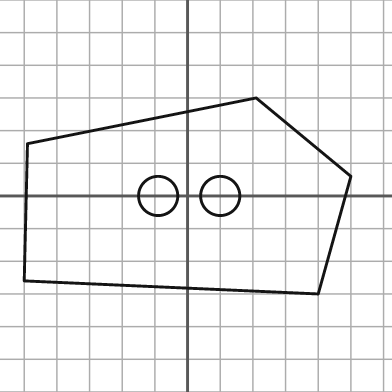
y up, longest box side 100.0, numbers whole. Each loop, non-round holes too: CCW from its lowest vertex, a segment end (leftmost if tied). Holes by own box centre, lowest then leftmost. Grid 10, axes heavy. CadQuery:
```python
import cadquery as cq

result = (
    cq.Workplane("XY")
    .moveTo(40.0, -30.0)
    .lineTo(50.0, 6.0)
    .lineTo(21.0, 30.0)
    .lineTo(-49.0, 16.0)
    .lineTo(-50.0, -26.0)
    .close()
    .moveTo(-9.0, 0.0)
    .circle(6.0)
    .moveTo(10.0, 0.0)
    .circle(6.0)
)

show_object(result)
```